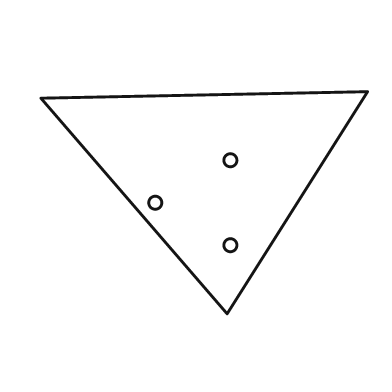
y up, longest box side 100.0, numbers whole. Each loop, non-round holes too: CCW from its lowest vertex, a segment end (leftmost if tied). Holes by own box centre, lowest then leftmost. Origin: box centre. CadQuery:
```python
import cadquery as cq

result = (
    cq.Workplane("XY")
    .moveTo(7.0, -34.0)
    .lineTo(50.0, 34.0)
    .lineTo(-50.0, 32.0)
    .close()
    .moveTo(8.0, -13.0)
    .circle(2.0)
    .moveTo(-15.0, 0.0)
    .circle(2.0)
    .moveTo(8.0, 13.0)
    .circle(2.0)
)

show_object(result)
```